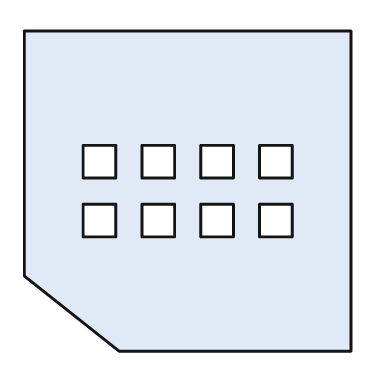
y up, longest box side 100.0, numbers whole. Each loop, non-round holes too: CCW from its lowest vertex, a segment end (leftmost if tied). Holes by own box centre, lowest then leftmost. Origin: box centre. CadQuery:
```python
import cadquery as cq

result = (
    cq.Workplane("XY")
    .moveTo(-21.0, -49.0)
    .lineTo(50.0, -49.0)
    .lineTo(50.0, 49.0)
    .lineTo(-50.0, 49.0)
    .lineTo(-50.0, -26.0)
    .close()
    .moveTo(-32.0, -14.0)
    .lineTo(-22.0, -14.0)
    .lineTo(-22.0, -4.0)
    .lineTo(-32.0, -4.0)
    .close()
    .moveTo(-14.0, -14.0)
    .lineTo(-4.0, -14.0)
    .lineTo(-4.0, -4.0)
    .lineTo(-14.0, -4.0)
    .close()
    .moveTo(4.0, -14.0)
    .lineTo(14.0, -14.0)
    .lineTo(14.0, -4.0)
    .lineTo(4.0, -4.0)
    .close()
    .moveTo(22.0, -14.0)
    .lineTo(32.0, -14.0)
    .lineTo(32.0, -4.0)
    .lineTo(22.0, -4.0)
    .close()
    .moveTo(-32.0, 4.0)
    .lineTo(-22.0, 4.0)
    .lineTo(-22.0, 14.0)
    .lineTo(-32.0, 14.0)
    .close()
    .moveTo(-14.0, 4.0)
    .lineTo(-4.0, 4.0)
    .lineTo(-4.0, 14.0)
    .lineTo(-14.0, 14.0)
    .close()
    .moveTo(4.0, 4.0)
    .lineTo(14.0, 4.0)
    .lineTo(14.0, 14.0)
    .lineTo(4.0, 14.0)
    .close()
    .moveTo(22.0, 4.0)
    .lineTo(32.0, 4.0)
    .lineTo(32.0, 14.0)
    .lineTo(22.0, 14.0)
    .close()
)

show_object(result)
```